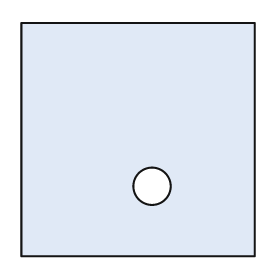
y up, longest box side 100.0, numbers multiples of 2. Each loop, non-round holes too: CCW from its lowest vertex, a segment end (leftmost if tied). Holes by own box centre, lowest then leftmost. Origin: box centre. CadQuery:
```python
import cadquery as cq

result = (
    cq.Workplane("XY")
    .moveTo(-50.0, -50.0)
    .lineTo(50.0, -50.0)
    .lineTo(50.0, 50.0)
    .lineTo(-50.0, 50.0)
    .close()
    .moveTo(6.0, -20.0)
    .circle(8.0)
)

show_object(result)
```